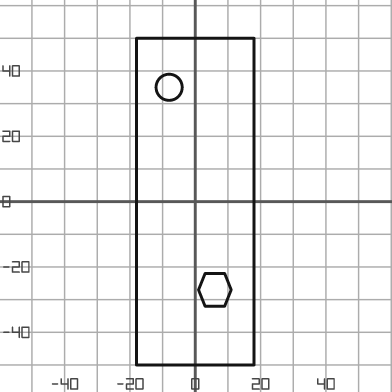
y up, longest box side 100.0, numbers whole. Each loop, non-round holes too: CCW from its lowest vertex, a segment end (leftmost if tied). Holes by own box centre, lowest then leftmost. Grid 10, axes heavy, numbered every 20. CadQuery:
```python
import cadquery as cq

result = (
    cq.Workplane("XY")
    .moveTo(-18.0, -50.0)
    .lineTo(18.0, -50.0)
    .lineTo(18.0, 50.0)
    .lineTo(-18.0, 50.0)
    .close()
    .moveTo(3.0, -32.0)
    .lineTo(9.0, -32.0)
    .lineTo(11.0, -27.0)
    .lineTo(9.0, -22.0)
    .lineTo(3.0, -22.0)
    .lineTo(1.0, -27.0)
    .close()
    .moveTo(-8.0, 35.0)
    .circle(4.0)
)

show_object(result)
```